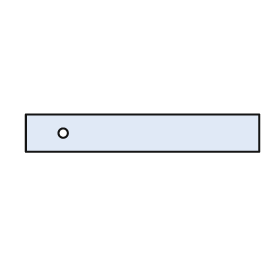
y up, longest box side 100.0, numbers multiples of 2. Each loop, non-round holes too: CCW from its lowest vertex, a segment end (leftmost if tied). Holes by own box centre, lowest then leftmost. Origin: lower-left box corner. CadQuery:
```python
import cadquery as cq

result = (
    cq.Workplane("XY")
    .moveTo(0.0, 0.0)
    .lineTo(100.0, 0.0)
    .lineTo(100.0, 16.0)
    .lineTo(0.0, 16.0)
    .close()
    .moveTo(16.0, 8.0)
    .circle(2.0)
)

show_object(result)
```